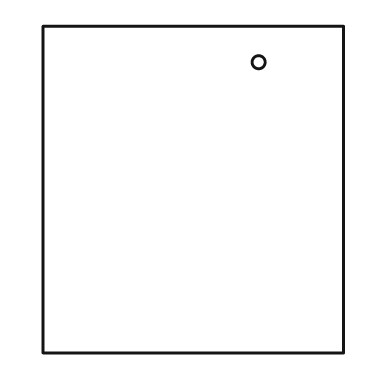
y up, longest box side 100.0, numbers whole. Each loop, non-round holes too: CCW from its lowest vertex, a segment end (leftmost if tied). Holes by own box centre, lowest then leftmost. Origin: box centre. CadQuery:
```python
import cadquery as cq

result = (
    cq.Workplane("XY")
    .moveTo(-46.0, -50.0)
    .lineTo(46.0, -50.0)
    .lineTo(46.0, 50.0)
    .lineTo(-46.0, 50.0)
    .close()
    .moveTo(20.0, 39.0)
    .circle(2.0)
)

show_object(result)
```